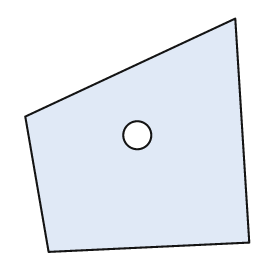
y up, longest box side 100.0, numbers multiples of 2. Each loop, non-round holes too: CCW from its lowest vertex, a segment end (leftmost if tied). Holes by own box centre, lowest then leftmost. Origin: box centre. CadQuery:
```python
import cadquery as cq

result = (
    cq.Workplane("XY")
    .moveTo(-38.0, -50.0)
    .lineTo(48.0, -46.0)
    .lineTo(42.0, 50.0)
    .lineTo(-48.0, 8.0)
    .close()
    .moveTo(0.0, 0.0)
    .circle(6.0)
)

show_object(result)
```